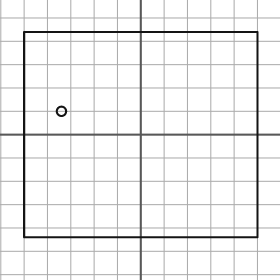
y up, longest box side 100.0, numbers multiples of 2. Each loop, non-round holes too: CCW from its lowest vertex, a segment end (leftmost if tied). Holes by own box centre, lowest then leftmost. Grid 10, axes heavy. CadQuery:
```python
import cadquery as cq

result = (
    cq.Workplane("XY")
    .moveTo(-50.0, -44.0)
    .lineTo(50.0, -44.0)
    .lineTo(50.0, 44.0)
    .lineTo(-50.0, 44.0)
    .close()
    .moveTo(-34.0, 10.0)
    .circle(2.0)
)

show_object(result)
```